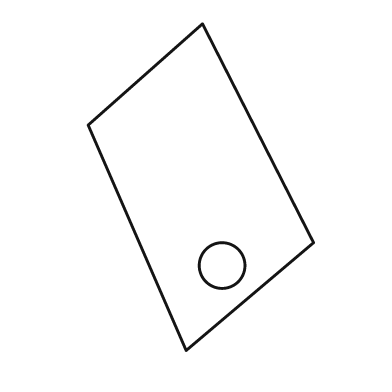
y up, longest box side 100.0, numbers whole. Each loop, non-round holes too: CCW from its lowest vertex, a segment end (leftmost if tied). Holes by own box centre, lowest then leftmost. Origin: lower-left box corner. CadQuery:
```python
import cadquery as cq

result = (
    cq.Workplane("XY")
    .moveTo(30.0, 0.0)
    .lineTo(69.0, 33.0)
    .lineTo(35.0, 100.0)
    .lineTo(0.0, 69.0)
    .close()
    .moveTo(41.0, 26.0)
    .circle(7.0)
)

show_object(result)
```